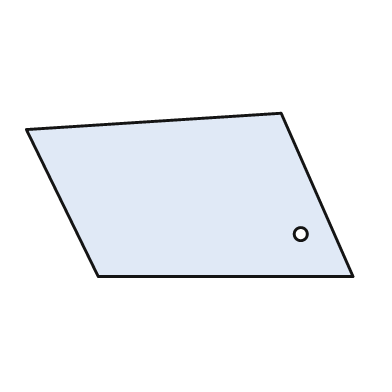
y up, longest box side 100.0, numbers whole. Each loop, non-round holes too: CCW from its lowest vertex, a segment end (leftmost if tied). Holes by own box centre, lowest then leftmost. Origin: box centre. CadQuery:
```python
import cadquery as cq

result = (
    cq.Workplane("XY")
    .moveTo(-28.0, -25.0)
    .lineTo(50.0, -25.0)
    .lineTo(28.0, 25.0)
    .lineTo(-50.0, 20.0)
    .close()
    .moveTo(34.0, -12.0)
    .circle(2.0)
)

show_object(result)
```